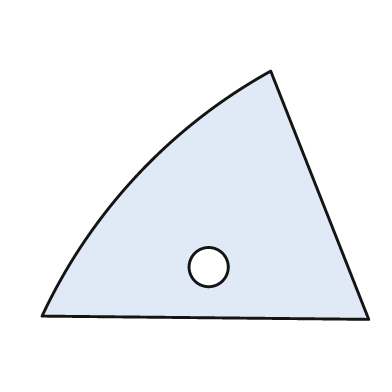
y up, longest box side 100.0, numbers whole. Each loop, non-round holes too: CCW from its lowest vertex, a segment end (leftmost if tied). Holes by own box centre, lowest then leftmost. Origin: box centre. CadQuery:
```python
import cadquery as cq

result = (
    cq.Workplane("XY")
    .moveTo(50.0, -38.0)
    .lineTo(20.0, 38.0)
    .threePointArc((-21.0, 6.0), (-50.0, -37.0))
    .close()
    .moveTo(1.0, -22.0)
    .circle(6.0)
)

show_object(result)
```